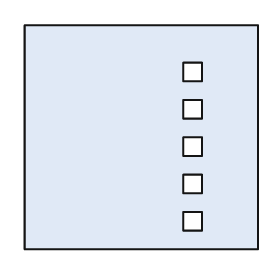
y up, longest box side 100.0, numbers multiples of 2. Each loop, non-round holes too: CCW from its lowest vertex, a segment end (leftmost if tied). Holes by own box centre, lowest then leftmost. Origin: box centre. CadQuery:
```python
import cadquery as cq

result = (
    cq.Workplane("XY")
    .moveTo(-50.0, -48.0)
    .lineTo(50.0, -48.0)
    .lineTo(50.0, 48.0)
    .lineTo(-50.0, 48.0)
    .close()
    .moveTo(18.0, -40.0)
    .lineTo(26.0, -40.0)
    .lineTo(26.0, -32.0)
    .lineTo(18.0, -32.0)
    .close()
    .moveTo(18.0, -24.0)
    .lineTo(26.0, -24.0)
    .lineTo(26.0, -16.0)
    .lineTo(18.0, -16.0)
    .close()
    .moveTo(18.0, -8.0)
    .lineTo(26.0, -8.0)
    .lineTo(26.0, 0.0)
    .lineTo(18.0, 0.0)
    .close()
    .moveTo(18.0, 8.0)
    .lineTo(26.0, 8.0)
    .lineTo(26.0, 16.0)
    .lineTo(18.0, 16.0)
    .close()
    .moveTo(18.0, 24.0)
    .lineTo(26.0, 24.0)
    .lineTo(26.0, 32.0)
    .lineTo(18.0, 32.0)
    .close()
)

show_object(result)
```